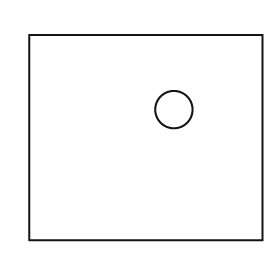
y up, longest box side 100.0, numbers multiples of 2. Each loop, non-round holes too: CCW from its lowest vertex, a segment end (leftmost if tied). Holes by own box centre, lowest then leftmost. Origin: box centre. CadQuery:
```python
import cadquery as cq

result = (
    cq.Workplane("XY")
    .moveTo(-50.0, -44.0)
    .lineTo(50.0, -44.0)
    .lineTo(50.0, 44.0)
    .lineTo(-50.0, 44.0)
    .close()
    .moveTo(12.0, 12.0)
    .circle(8.0)
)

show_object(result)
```